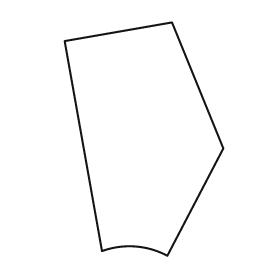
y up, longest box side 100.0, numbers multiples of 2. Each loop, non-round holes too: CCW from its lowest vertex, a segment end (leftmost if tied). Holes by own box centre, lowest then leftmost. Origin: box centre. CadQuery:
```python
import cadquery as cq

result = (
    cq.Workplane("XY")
    .moveTo(10.0, -50.0)
    .lineTo(34.0, -4.0)
    .lineTo(12.0, 50.0)
    .lineTo(-34.0, 42.0)
    .lineTo(-18.0, -48.0)
    .threePointArc((-4.0, -46.0), (10.0, -50.0))
    .close()
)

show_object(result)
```